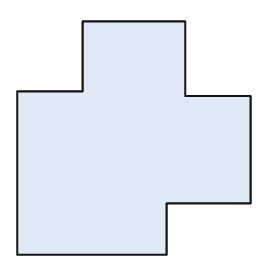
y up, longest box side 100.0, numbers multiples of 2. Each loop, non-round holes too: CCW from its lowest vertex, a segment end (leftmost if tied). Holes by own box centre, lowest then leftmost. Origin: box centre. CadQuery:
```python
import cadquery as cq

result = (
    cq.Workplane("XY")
    .moveTo(-50.0, -50.0)
    .lineTo(14.0, -50.0)
    .lineTo(14.0, -28.0)
    .lineTo(50.0, -28.0)
    .lineTo(50.0, 18.0)
    .lineTo(22.0, 18.0)
    .lineTo(22.0, 50.0)
    .lineTo(-22.0, 50.0)
    .lineTo(-22.0, 20.0)
    .lineTo(-50.0, 20.0)
    .close()
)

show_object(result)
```